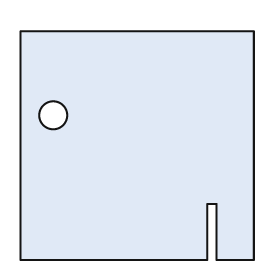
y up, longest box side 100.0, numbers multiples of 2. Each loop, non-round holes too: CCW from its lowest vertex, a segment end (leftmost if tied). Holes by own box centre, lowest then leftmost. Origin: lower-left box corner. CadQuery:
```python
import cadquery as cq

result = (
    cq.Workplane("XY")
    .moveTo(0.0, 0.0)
    .lineTo(80.0, 0.0)
    .lineTo(80.0, 24.0)
    .lineTo(84.0, 24.0)
    .lineTo(84.0, 0.0)
    .lineTo(100.0, 0.0)
    .lineTo(100.0, 98.0)
    .lineTo(0.0, 98.0)
    .close()
    .moveTo(14.0, 62.0)
    .circle(6.0)
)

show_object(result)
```